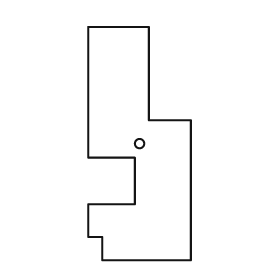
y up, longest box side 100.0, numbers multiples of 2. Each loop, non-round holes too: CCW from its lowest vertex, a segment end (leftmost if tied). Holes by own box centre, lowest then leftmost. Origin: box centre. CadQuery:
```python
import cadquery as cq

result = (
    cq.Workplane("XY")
    .moveTo(-16.0, -50.0)
    .lineTo(22.0, -50.0)
    .lineTo(22.0, 10.0)
    .lineTo(4.0, 10.0)
    .lineTo(4.0, 50.0)
    .lineTo(-22.0, 50.0)
    .lineTo(-22.0, -6.0)
    .lineTo(-2.0, -6.0)
    .lineTo(-2.0, -26.0)
    .lineTo(-22.0, -26.0)
    .lineTo(-22.0, -40.0)
    .lineTo(-16.0, -40.0)
    .close()
    .moveTo(0.0, 0.0)
    .circle(2.0)
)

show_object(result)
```